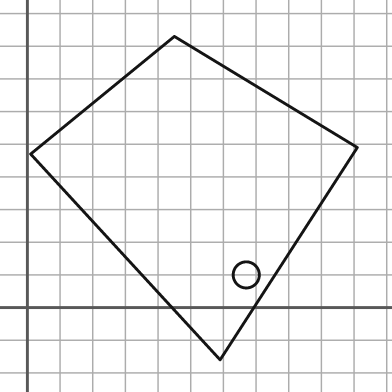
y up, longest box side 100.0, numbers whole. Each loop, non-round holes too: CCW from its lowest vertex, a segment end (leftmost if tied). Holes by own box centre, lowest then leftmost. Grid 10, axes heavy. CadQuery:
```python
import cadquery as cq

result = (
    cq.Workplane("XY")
    .moveTo(59.0, -16.0)
    .lineTo(101.0, 49.0)
    .lineTo(45.0, 83.0)
    .lineTo(1.0, 47.0)
    .close()
    .moveTo(67.0, 10.0)
    .circle(4.0)
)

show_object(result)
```